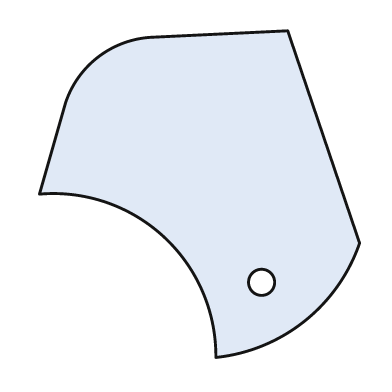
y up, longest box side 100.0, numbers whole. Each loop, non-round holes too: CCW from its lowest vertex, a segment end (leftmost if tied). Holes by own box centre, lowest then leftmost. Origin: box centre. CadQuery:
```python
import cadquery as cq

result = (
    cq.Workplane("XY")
    .moveTo(5.0, -50.0)
    .threePointArc((32.0, -39.0), (49.0, -15.0))
    .lineTo(27.0, 50.0)
    .lineTo(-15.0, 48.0)
    .threePointArc((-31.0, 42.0), (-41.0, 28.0))
    .lineTo(-49.0, 0.0)
    .threePointArc((-11.0, -13.0), (5.0, -50.0))
    .close()
    .moveTo(19.0, -27.0)
    .circle(4.0)
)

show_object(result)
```